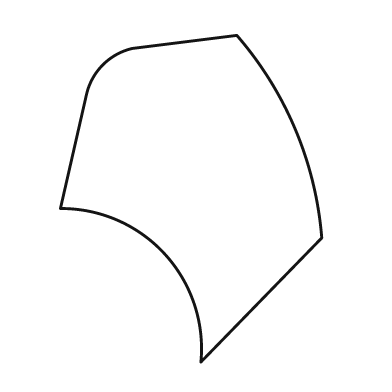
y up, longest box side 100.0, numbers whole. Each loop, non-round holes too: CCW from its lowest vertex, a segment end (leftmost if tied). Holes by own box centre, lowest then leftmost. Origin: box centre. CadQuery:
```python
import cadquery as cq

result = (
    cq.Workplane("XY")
    .moveTo(3.0, -50.0)
    .lineTo(40.0, -12.0)
    .threePointArc((32.0, 21.0), (14.0, 50.0))
    .lineTo(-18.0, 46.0)
    .threePointArc((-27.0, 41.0), (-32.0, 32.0))
    .lineTo(-40.0, -3.0)
    .threePointArc((-8.0, -17.0), (3.0, -50.0))
    .close()
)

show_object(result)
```